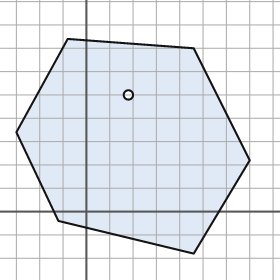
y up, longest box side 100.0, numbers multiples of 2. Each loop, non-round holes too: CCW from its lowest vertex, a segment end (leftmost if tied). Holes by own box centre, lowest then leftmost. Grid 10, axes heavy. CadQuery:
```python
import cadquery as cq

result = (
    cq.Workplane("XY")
    .moveTo(46.0, -18.0)
    .lineTo(70.0, 22.0)
    .lineTo(46.0, 70.0)
    .lineTo(-8.0, 74.0)
    .lineTo(-30.0, 34.0)
    .lineTo(-12.0, -4.0)
    .close()
    .moveTo(18.0, 50.0)
    .circle(2.0)
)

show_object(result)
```